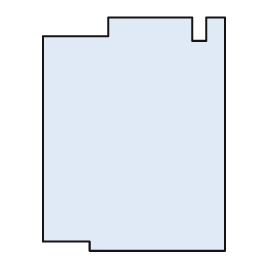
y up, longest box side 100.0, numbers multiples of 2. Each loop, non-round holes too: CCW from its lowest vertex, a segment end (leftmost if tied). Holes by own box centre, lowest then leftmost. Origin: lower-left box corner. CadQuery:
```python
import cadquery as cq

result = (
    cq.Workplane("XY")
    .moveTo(20.0, 0.0)
    .lineTo(78.0, 0.0)
    .lineTo(78.0, 100.0)
    .lineTo(70.0, 100.0)
    .lineTo(70.0, 90.0)
    .lineTo(64.0, 90.0)
    .lineTo(64.0, 100.0)
    .lineTo(28.0, 100.0)
    .lineTo(28.0, 92.0)
    .lineTo(0.0, 92.0)
    .lineTo(0.0, 4.0)
    .lineTo(20.0, 4.0)
    .close()
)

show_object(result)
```